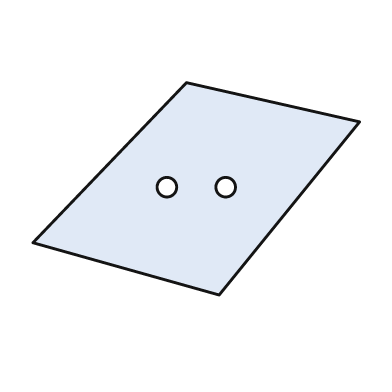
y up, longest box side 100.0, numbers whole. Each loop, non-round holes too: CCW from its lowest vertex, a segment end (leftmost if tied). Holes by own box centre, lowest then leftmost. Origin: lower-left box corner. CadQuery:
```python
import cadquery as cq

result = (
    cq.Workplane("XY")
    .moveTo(57.0, 0.0)
    .lineTo(100.0, 53.0)
    .lineTo(47.0, 65.0)
    .lineTo(0.0, 16.0)
    .close()
    .moveTo(41.0, 33.0)
    .circle(3.0)
    .moveTo(59.0, 33.0)
    .circle(3.0)
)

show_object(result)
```